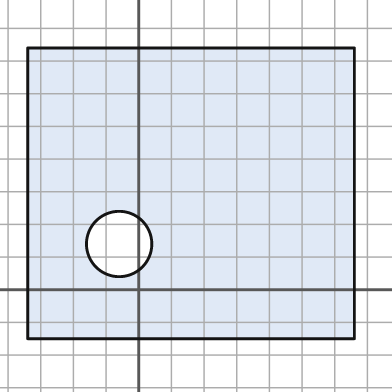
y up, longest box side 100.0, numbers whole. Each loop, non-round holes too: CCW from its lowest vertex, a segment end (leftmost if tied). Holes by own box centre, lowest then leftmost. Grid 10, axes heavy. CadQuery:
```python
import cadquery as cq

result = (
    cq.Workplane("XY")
    .moveTo(-34.0, -15.0)
    .lineTo(66.0, -15.0)
    .lineTo(66.0, 74.0)
    .lineTo(-34.0, 74.0)
    .close()
    .moveTo(-6.0, 14.0)
    .circle(10.0)
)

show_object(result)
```